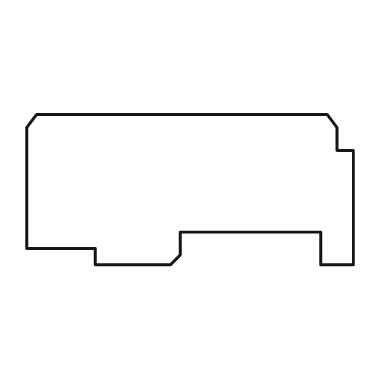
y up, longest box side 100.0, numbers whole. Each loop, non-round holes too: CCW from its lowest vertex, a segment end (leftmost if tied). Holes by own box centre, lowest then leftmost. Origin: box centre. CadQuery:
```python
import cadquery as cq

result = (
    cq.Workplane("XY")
    .moveTo(-29.0, -23.0)
    .lineTo(-6.0, -23.0)
    .lineTo(-3.0, -20.0)
    .lineTo(-3.0, -13.0)
    .lineTo(40.0, -13.0)
    .lineTo(40.0, -23.0)
    .lineTo(50.0, -23.0)
    .lineTo(50.0, 12.0)
    .lineTo(45.0, 12.0)
    .lineTo(45.0, 19.0)
    .lineTo(42.0, 23.0)
    .lineTo(-47.0, 23.0)
    .lineTo(-50.0, 19.0)
    .lineTo(-50.0, -18.0)
    .lineTo(-29.0, -18.0)
    .close()
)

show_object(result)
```